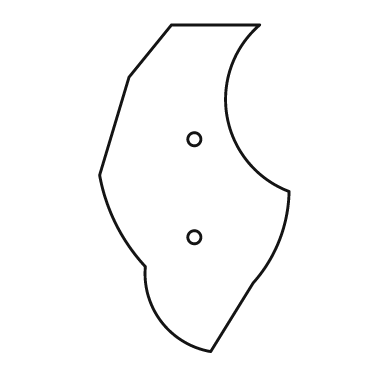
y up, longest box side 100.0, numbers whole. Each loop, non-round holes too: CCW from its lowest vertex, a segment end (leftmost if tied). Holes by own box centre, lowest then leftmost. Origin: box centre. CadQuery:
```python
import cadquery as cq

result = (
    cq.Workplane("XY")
    .moveTo(5.0, -50.0)
    .lineTo(18.0, -29.0)
    .threePointArc((26.0, -16.0), (29.0, -1.0))
    .threePointArc((10.0, 22.0), (20.0, 50.0))
    .lineTo(-7.0, 50.0)
    .lineTo(-20.0, 34.0)
    .lineTo(-29.0, 4.0)
    .threePointArc((-24.0, -11.0), (-15.0, -24.0))
    .threePointArc((-10.0, -41.0), (5.0, -50.0))
    .close()
    .moveTo(0.0, -15.0)
    .circle(2.0)
    .moveTo(0.0, 15.0)
    .circle(2.0)
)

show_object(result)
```